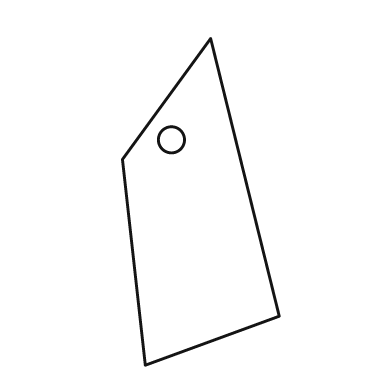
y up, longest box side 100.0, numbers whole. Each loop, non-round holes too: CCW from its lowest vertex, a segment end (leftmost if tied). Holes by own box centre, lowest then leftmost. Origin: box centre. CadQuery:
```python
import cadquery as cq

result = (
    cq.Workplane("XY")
    .moveTo(-17.0, -50.0)
    .lineTo(24.0, -35.0)
    .lineTo(3.0, 50.0)
    .lineTo(-24.0, 13.0)
    .close()
    .moveTo(-9.0, 19.0)
    .circle(4.0)
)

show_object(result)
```